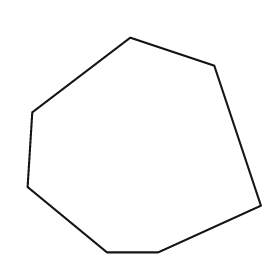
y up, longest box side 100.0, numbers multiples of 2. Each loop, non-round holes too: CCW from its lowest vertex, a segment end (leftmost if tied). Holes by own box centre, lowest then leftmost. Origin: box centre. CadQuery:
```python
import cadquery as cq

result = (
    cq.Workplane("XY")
    .moveTo(-16.0, -46.0)
    .lineTo(6.0, -46.0)
    .lineTo(50.0, -26.0)
    .lineTo(30.0, 34.0)
    .lineTo(-6.0, 46.0)
    .lineTo(-48.0, 14.0)
    .lineTo(-50.0, -18.0)
    .close()
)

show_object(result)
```